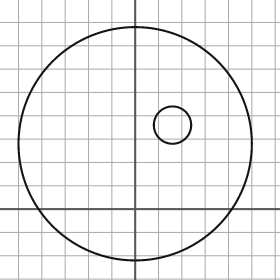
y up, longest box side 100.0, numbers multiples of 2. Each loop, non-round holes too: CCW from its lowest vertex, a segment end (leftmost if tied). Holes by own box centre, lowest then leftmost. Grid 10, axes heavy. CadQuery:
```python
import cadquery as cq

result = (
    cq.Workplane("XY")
    .moveTo(0.0, 28.0)
    .circle(50.0)
    .moveTo(16.0, 36.0)
    .circle(8.0)
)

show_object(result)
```